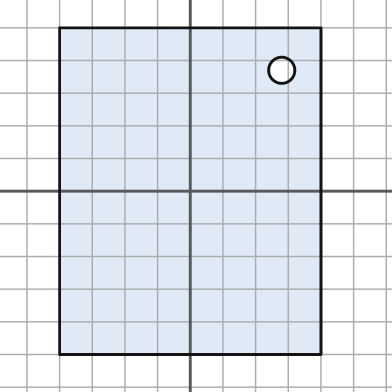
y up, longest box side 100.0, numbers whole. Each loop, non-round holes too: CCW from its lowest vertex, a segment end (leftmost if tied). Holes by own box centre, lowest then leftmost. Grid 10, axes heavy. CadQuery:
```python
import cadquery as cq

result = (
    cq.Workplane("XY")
    .moveTo(-40.0, -50.0)
    .lineTo(40.0, -50.0)
    .lineTo(40.0, 50.0)
    .lineTo(-40.0, 50.0)
    .close()
    .moveTo(28.0, 37.0)
    .circle(4.0)
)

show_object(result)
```